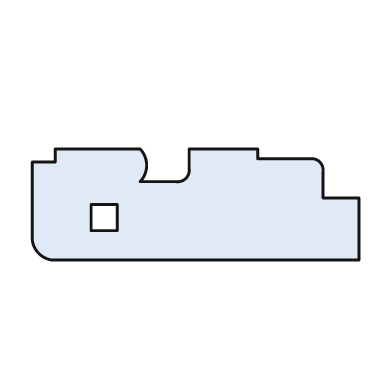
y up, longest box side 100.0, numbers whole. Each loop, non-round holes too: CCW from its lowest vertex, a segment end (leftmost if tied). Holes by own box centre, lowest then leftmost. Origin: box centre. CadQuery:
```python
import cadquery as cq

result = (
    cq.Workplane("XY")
    .moveTo(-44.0, -17.0)
    .lineTo(50.0, -17.0)
    .lineTo(50.0, 2.0)
    .lineTo(39.0, 2.0)
    .lineTo(39.0, 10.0)
    .threePointArc((38.0, 13.0), (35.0, 14.0))
    .lineTo(19.0, 14.0)
    .lineTo(19.0, 17.0)
    .lineTo(-2.0, 17.0)
    .lineTo(-2.0, 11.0)
    .threePointArc((-3.0, 8.0), (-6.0, 7.0))
    .lineTo(-17.0, 7.0)
    .threePointArc((-15.0, 12.0), (-17.0, 17.0))
    .lineTo(-43.0, 17.0)
    .lineTo(-43.0, 13.0)
    .lineTo(-50.0, 13.0)
    .lineTo(-50.0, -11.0)
    .threePointArc((-48.0, -15.0), (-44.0, -17.0))
    .close()
    .moveTo(-32.0, -8.0)
    .lineTo(-24.0, -8.0)
    .lineTo(-24.0, 0.0)
    .lineTo(-32.0, 0.0)
    .close()
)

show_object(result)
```